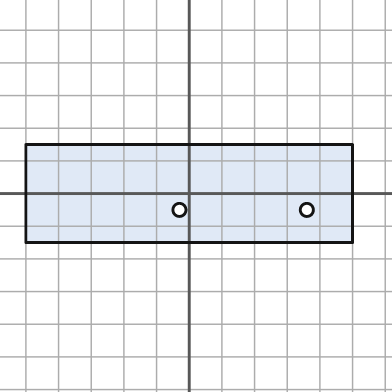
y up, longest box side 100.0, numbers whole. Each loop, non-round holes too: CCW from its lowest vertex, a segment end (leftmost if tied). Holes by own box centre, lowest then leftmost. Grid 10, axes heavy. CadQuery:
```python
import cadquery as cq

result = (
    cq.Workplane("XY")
    .moveTo(-50.0, -15.0)
    .lineTo(50.0, -15.0)
    .lineTo(50.0, 15.0)
    .lineTo(-50.0, 15.0)
    .close()
    .moveTo(-3.0, -5.0)
    .circle(2.0)
    .moveTo(36.0, -5.0)
    .circle(2.0)
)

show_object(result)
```